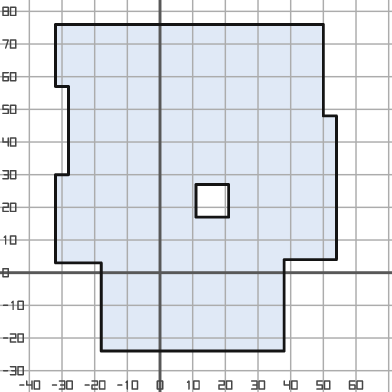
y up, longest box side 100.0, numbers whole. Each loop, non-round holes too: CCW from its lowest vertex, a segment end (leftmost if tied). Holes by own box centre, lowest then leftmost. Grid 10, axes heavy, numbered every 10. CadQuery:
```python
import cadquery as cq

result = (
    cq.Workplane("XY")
    .moveTo(-18.0, -24.0)
    .lineTo(38.0, -24.0)
    .lineTo(38.0, 4.0)
    .lineTo(54.0, 4.0)
    .lineTo(54.0, 48.0)
    .lineTo(50.0, 48.0)
    .lineTo(50.0, 76.0)
    .lineTo(-32.0, 76.0)
    .lineTo(-32.0, 57.0)
    .lineTo(-28.0, 57.0)
    .lineTo(-28.0, 30.0)
    .lineTo(-32.0, 30.0)
    .lineTo(-32.0, 3.0)
    .lineTo(-18.0, 3.0)
    .close()
    .moveTo(11.0, 17.0)
    .lineTo(21.0, 17.0)
    .lineTo(21.0, 27.0)
    .lineTo(11.0, 27.0)
    .close()
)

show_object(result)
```